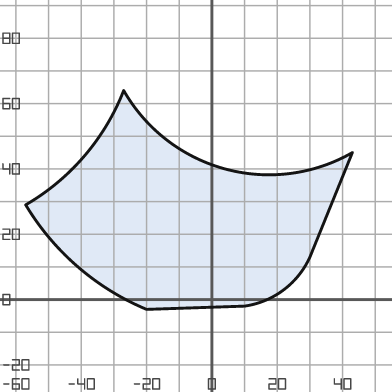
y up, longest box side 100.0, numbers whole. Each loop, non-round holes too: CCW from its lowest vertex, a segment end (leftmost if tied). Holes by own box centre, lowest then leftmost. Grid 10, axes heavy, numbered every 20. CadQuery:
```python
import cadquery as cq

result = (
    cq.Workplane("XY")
    .moveTo(-20.0, -3.0)
    .lineTo(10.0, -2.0)
    .threePointArc((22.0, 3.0), (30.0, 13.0))
    .lineTo(43.0, 45.0)
    .threePointArc((4.0, 40.0), (-27.0, 64.0))
    .threePointArc((-39.0, 44.0), (-57.0, 29.0))
    .threePointArc((-41.0, 10.0), (-20.0, -3.0))
    .close()
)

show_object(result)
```